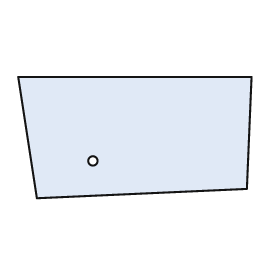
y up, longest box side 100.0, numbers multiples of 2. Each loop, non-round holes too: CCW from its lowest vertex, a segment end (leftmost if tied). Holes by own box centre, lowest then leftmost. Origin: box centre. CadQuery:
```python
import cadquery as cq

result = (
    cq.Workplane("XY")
    .moveTo(-42.0, -26.0)
    .lineTo(48.0, -22.0)
    .lineTo(50.0, 26.0)
    .lineTo(-50.0, 26.0)
    .close()
    .moveTo(-18.0, -10.0)
    .circle(2.0)
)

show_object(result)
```